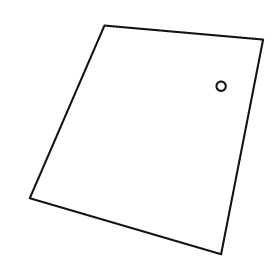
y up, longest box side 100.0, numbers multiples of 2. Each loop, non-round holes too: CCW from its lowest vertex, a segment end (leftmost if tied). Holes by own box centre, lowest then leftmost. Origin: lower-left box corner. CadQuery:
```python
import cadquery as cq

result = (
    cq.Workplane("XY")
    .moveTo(82.0, 0.0)
    .lineTo(100.0, 92.0)
    .lineTo(32.0, 98.0)
    .lineTo(0.0, 24.0)
    .close()
    .moveTo(82.0, 72.0)
    .circle(2.0)
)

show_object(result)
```